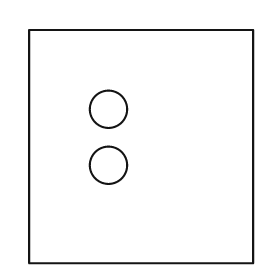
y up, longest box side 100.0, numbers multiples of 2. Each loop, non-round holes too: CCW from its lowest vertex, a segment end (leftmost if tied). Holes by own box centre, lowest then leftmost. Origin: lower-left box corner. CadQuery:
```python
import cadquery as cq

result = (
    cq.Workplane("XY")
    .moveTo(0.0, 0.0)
    .lineTo(96.0, 0.0)
    .lineTo(96.0, 100.0)
    .lineTo(0.0, 100.0)
    .close()
    .moveTo(34.0, 42.0)
    .circle(8.0)
    .moveTo(34.0, 66.0)
    .circle(8.0)
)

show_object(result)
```